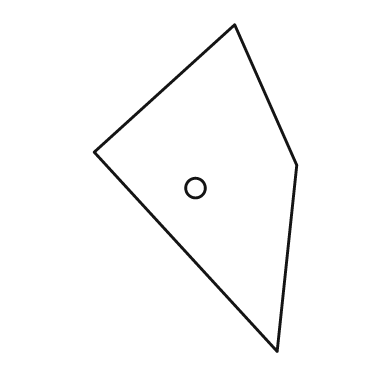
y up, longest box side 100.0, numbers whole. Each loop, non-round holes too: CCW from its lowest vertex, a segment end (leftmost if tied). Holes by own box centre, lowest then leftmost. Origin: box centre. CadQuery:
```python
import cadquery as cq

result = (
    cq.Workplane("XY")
    .moveTo(25.0, -50.0)
    .lineTo(31.0, 7.0)
    .lineTo(12.0, 50.0)
    .lineTo(-31.0, 11.0)
    .close()
    .moveTo(0.0, 0.0)
    .circle(3.0)
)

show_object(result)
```